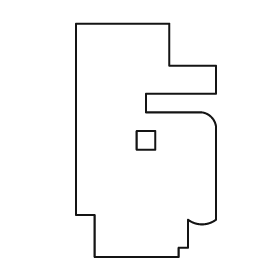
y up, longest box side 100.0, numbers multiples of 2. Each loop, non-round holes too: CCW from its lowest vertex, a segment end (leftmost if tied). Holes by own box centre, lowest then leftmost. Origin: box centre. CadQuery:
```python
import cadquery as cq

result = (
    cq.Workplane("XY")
    .moveTo(-22.0, -50.0)
    .lineTo(14.0, -50.0)
    .lineTo(14.0, -46.0)
    .lineTo(18.0, -46.0)
    .lineTo(18.0, -34.0)
    .threePointArc((24.0, -36.0), (30.0, -34.0))
    .lineTo(30.0, 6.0)
    .threePointArc((28.0, 10.0), (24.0, 12.0))
    .lineTo(0.0, 12.0)
    .lineTo(0.0, 20.0)
    .lineTo(30.0, 20.0)
    .lineTo(30.0, 32.0)
    .lineTo(10.0, 32.0)
    .lineTo(10.0, 50.0)
    .lineTo(-30.0, 50.0)
    .lineTo(-30.0, -32.0)
    .lineTo(-22.0, -32.0)
    .close()
    .moveTo(-4.0, -4.0)
    .lineTo(4.0, -4.0)
    .lineTo(4.0, 4.0)
    .lineTo(-4.0, 4.0)
    .close()
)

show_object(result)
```